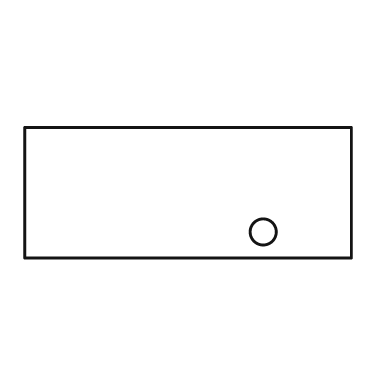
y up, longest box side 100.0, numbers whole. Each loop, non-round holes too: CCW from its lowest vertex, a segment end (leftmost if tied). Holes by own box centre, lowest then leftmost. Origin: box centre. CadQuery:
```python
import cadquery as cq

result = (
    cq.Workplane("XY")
    .moveTo(-50.0, -20.0)
    .lineTo(50.0, -20.0)
    .lineTo(50.0, 20.0)
    .lineTo(-50.0, 20.0)
    .close()
    .moveTo(23.0, -12.0)
    .circle(4.0)
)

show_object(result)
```